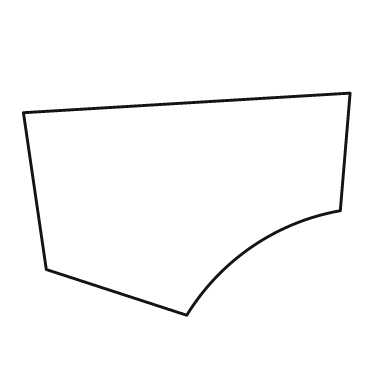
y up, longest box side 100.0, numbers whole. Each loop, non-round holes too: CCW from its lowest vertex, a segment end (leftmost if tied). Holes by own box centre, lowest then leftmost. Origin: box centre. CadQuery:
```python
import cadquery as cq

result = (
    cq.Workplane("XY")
    .moveTo(0.0, -34.0)
    .threePointArc((20.0, -13.0), (47.0, -2.0))
    .lineTo(50.0, 34.0)
    .lineTo(-50.0, 28.0)
    .lineTo(-43.0, -20.0)
    .close()
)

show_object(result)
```